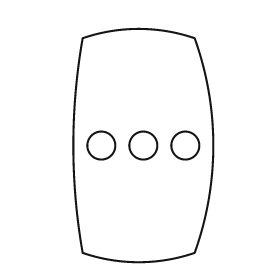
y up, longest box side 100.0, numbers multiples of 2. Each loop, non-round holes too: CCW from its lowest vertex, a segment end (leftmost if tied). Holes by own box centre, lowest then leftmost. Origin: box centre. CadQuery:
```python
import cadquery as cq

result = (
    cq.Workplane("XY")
    .moveTo(-26.0, -46.0)
    .threePointArc((-2.0, -50.0), (22.0, -46.0))
    .threePointArc((30.0, 0.0), (22.0, 46.0))
    .threePointArc((-2.0, 50.0), (-26.0, 46.0))
    .threePointArc((-30.0, 0.0), (-26.0, -46.0))
    .close()
    .moveTo(-18.0, 0.0)
    .circle(6.0)
    .moveTo(0.0, 0.0)
    .circle(6.0)
    .moveTo(18.0, 0.0)
    .circle(6.0)
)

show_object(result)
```